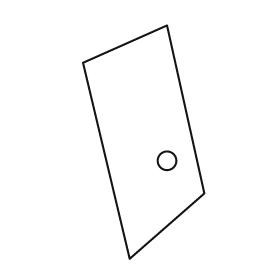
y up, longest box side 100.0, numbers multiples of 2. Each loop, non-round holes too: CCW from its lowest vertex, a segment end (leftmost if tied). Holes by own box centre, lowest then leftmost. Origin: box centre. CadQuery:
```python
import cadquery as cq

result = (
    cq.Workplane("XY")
    .moveTo(-6.0, -50.0)
    .lineTo(26.0, -22.0)
    .lineTo(10.0, 50.0)
    .lineTo(-26.0, 34.0)
    .close()
    .moveTo(10.0, -8.0)
    .circle(4.0)
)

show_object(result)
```